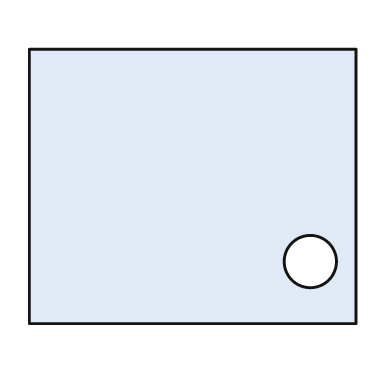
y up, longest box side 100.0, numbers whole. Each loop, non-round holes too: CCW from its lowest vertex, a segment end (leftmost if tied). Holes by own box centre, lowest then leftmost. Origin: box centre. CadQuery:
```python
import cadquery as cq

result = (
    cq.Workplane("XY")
    .moveTo(-50.0, -42.0)
    .lineTo(50.0, -42.0)
    .lineTo(50.0, 42.0)
    .lineTo(-50.0, 42.0)
    .close()
    .moveTo(36.0, -23.0)
    .circle(8.0)
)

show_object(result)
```